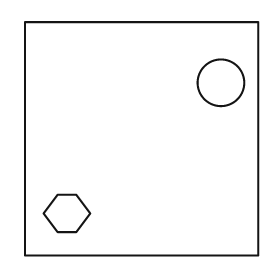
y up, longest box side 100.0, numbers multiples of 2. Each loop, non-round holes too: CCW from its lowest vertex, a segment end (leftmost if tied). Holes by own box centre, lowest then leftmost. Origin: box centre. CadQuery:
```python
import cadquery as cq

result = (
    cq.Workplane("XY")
    .moveTo(-50.0, -50.0)
    .lineTo(50.0, -50.0)
    .lineTo(50.0, 50.0)
    .lineTo(-50.0, 50.0)
    .close()
    .moveTo(-36.0, -40.0)
    .lineTo(-28.0, -40.0)
    .lineTo(-22.0, -32.0)
    .lineTo(-28.0, -24.0)
    .lineTo(-36.0, -24.0)
    .lineTo(-42.0, -32.0)
    .close()
    .moveTo(34.0, 24.0)
    .circle(10.0)
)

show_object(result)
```